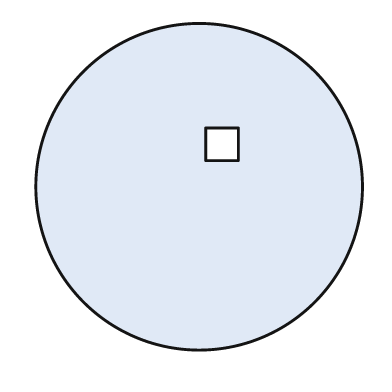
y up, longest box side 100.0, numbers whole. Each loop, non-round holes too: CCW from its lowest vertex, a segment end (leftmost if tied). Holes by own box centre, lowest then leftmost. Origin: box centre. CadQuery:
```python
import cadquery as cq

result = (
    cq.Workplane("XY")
    .moveTo(0.0, 0.0)
    .circle(50.0)
    .moveTo(2.0, 8.0)
    .lineTo(12.0, 8.0)
    .lineTo(12.0, 18.0)
    .lineTo(2.0, 18.0)
    .close()
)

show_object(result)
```